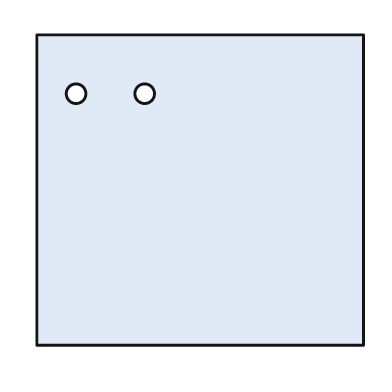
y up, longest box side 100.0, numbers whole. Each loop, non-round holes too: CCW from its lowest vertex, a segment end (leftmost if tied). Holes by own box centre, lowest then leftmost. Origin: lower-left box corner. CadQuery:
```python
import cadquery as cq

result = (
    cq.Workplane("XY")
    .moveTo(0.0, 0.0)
    .lineTo(100.0, 0.0)
    .lineTo(100.0, 95.0)
    .lineTo(0.0, 95.0)
    .close()
    .moveTo(12.0, 77.0)
    .circle(3.0)
    .moveTo(33.0, 77.0)
    .circle(3.0)
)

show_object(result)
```